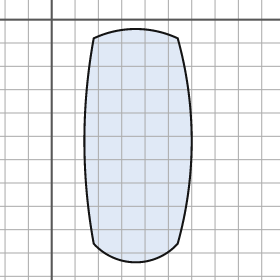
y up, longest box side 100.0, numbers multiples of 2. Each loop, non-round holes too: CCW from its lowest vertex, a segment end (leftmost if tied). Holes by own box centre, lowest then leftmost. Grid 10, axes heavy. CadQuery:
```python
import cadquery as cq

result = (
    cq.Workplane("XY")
    .moveTo(18.0, -96.0)
    .threePointArc((36.0, -104.0), (54.0, -96.0))
    .threePointArc((60.0, -52.0), (54.0, -8.0))
    .threePointArc((36.0, -4.0), (18.0, -8.0))
    .threePointArc((14.0, -52.0), (18.0, -96.0))
    .close()
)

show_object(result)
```